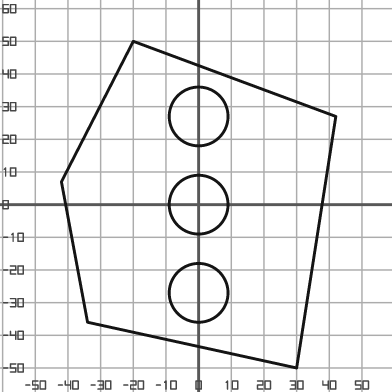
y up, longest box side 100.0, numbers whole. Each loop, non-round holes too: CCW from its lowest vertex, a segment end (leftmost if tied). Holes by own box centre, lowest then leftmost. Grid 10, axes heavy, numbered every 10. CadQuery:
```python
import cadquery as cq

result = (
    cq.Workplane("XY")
    .moveTo(30.0, -50.0)
    .lineTo(42.0, 27.0)
    .lineTo(-20.0, 50.0)
    .lineTo(-42.0, 7.0)
    .lineTo(-34.0, -36.0)
    .close()
    .moveTo(0.0, -27.0)
    .circle(9.0)
    .moveTo(0.0, 0.0)
    .circle(9.0)
    .moveTo(0.0, 27.0)
    .circle(9.0)
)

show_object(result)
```